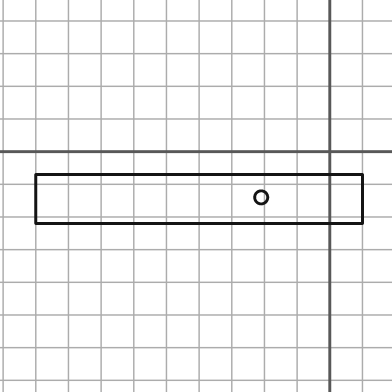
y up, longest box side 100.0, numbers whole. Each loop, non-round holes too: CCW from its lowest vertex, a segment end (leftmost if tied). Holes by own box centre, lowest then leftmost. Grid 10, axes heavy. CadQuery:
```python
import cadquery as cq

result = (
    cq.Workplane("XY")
    .moveTo(-90.0, -22.0)
    .lineTo(10.0, -22.0)
    .lineTo(10.0, -7.0)
    .lineTo(-90.0, -7.0)
    .close()
    .moveTo(-21.0, -14.0)
    .circle(2.0)
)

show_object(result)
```